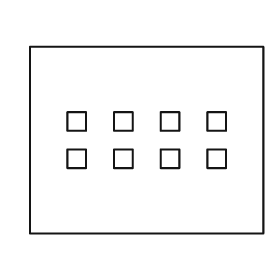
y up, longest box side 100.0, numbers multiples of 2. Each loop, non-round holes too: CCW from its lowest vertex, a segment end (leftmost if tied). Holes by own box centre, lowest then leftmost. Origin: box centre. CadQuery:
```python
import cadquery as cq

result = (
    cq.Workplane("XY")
    .moveTo(-50.0, -40.0)
    .lineTo(50.0, -40.0)
    .lineTo(50.0, 40.0)
    .lineTo(-50.0, 40.0)
    .close()
    .moveTo(-34.0, -12.0)
    .lineTo(-26.0, -12.0)
    .lineTo(-26.0, -4.0)
    .lineTo(-34.0, -4.0)
    .close()
    .moveTo(-14.0, -12.0)
    .lineTo(-6.0, -12.0)
    .lineTo(-6.0, -4.0)
    .lineTo(-14.0, -4.0)
    .close()
    .moveTo(6.0, -12.0)
    .lineTo(14.0, -12.0)
    .lineTo(14.0, -4.0)
    .lineTo(6.0, -4.0)
    .close()
    .moveTo(26.0, -12.0)
    .lineTo(34.0, -12.0)
    .lineTo(34.0, -4.0)
    .lineTo(26.0, -4.0)
    .close()
    .moveTo(-34.0, 4.0)
    .lineTo(-26.0, 4.0)
    .lineTo(-26.0, 12.0)
    .lineTo(-34.0, 12.0)
    .close()
    .moveTo(-14.0, 4.0)
    .lineTo(-6.0, 4.0)
    .lineTo(-6.0, 12.0)
    .lineTo(-14.0, 12.0)
    .close()
    .moveTo(6.0, 4.0)
    .lineTo(14.0, 4.0)
    .lineTo(14.0, 12.0)
    .lineTo(6.0, 12.0)
    .close()
    .moveTo(26.0, 4.0)
    .lineTo(34.0, 4.0)
    .lineTo(34.0, 12.0)
    .lineTo(26.0, 12.0)
    .close()
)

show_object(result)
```